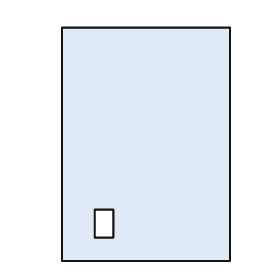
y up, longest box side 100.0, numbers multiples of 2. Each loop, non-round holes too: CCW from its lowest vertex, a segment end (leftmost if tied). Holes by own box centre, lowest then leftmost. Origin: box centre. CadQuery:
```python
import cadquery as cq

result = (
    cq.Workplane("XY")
    .moveTo(-36.0, -50.0)
    .lineTo(36.0, -50.0)
    .lineTo(36.0, 50.0)
    .lineTo(-36.0, 50.0)
    .close()
    .moveTo(-22.0, -40.0)
    .lineTo(-14.0, -40.0)
    .lineTo(-14.0, -28.0)
    .lineTo(-22.0, -28.0)
    .close()
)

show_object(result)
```